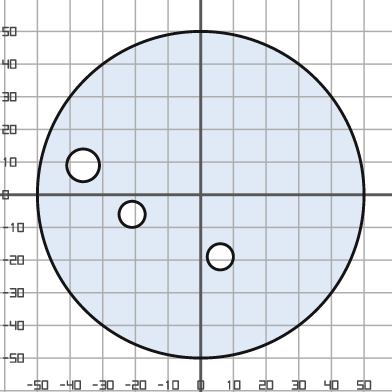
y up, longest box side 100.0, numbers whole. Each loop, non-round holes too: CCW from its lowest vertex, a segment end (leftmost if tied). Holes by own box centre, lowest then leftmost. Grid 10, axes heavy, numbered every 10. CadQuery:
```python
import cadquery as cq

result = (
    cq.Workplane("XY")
    .moveTo(0.0, 0.0)
    .circle(50.0)
    .moveTo(6.0, -19.0)
    .circle(4.0)
    .moveTo(-21.0, -6.0)
    .circle(4.0)
    .moveTo(-36.0, 9.0)
    .circle(5.0)
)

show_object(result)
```